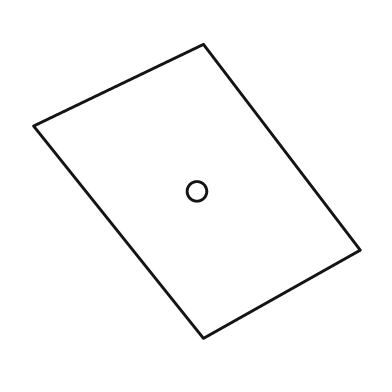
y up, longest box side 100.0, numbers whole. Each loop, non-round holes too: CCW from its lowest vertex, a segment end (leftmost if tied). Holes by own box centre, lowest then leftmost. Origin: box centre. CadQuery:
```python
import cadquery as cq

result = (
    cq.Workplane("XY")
    .moveTo(2.0, -45.0)
    .lineTo(50.0, -18.0)
    .lineTo(2.0, 45.0)
    .lineTo(-50.0, 20.0)
    .close()
    .moveTo(0.0, 0.0)
    .circle(3.0)
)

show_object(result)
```